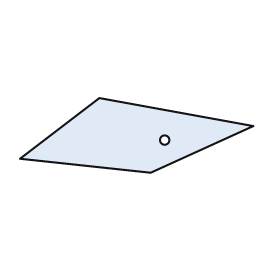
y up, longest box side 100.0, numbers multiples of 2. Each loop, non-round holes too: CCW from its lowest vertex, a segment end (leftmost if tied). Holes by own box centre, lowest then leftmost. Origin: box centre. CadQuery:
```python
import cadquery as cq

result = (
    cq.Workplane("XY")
    .moveTo(6.0, -16.0)
    .lineTo(50.0, 4.0)
    .lineTo(-16.0, 16.0)
    .lineTo(-50.0, -10.0)
    .close()
    .moveTo(12.0, -2.0)
    .circle(2.0)
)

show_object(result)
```